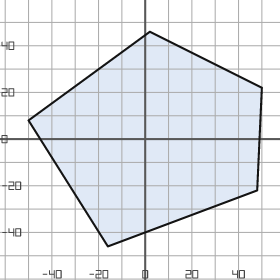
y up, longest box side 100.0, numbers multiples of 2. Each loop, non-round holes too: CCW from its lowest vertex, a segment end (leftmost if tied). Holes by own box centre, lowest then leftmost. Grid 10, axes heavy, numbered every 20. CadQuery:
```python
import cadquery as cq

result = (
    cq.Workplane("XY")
    .moveTo(-16.0, -46.0)
    .lineTo(48.0, -22.0)
    .lineTo(50.0, 22.0)
    .lineTo(2.0, 46.0)
    .lineTo(-50.0, 8.0)
    .close()
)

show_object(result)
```